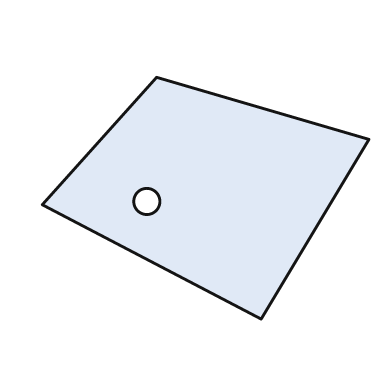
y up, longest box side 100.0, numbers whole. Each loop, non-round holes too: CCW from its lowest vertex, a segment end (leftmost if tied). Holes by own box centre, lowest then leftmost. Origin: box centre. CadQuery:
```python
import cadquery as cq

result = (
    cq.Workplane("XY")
    .moveTo(17.0, -37.0)
    .lineTo(50.0, 18.0)
    .lineTo(-15.0, 37.0)
    .lineTo(-50.0, -2.0)
    .close()
    .moveTo(-18.0, -1.0)
    .circle(4.0)
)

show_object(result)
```